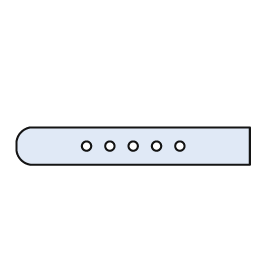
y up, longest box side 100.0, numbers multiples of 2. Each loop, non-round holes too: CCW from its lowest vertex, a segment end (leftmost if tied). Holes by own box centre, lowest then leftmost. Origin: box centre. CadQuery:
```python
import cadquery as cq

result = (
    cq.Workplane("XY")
    .moveTo(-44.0, -8.0)
    .lineTo(50.0, -8.0)
    .lineTo(50.0, 8.0)
    .lineTo(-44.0, 8.0)
    .threePointArc((-48.0, 6.0), (-50.0, 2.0))
    .lineTo(-50.0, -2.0)
    .threePointArc((-48.0, -6.0), (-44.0, -8.0))
    .close()
    .moveTo(-20.0, 0.0)
    .circle(2.0)
    .moveTo(-10.0, 0.0)
    .circle(2.0)
    .moveTo(0.0, 0.0)
    .circle(2.0)
    .moveTo(10.0, 0.0)
    .circle(2.0)
    .moveTo(20.0, 0.0)
    .circle(2.0)
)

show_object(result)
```